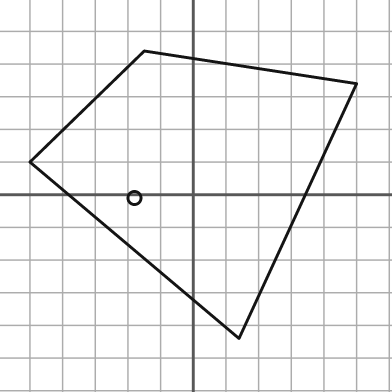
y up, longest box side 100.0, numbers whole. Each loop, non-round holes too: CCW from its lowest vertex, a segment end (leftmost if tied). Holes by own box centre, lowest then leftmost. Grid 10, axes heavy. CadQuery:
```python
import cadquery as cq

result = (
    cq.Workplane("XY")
    .moveTo(14.0, -44.0)
    .lineTo(50.0, 34.0)
    .lineTo(-15.0, 44.0)
    .lineTo(-50.0, 10.0)
    .close()
    .moveTo(-18.0, -1.0)
    .circle(2.0)
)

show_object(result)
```